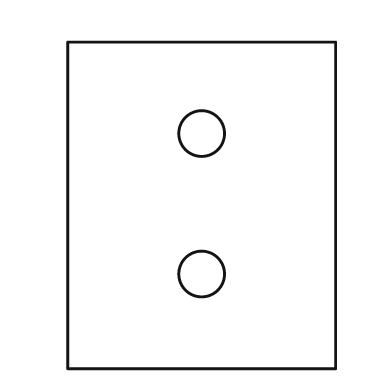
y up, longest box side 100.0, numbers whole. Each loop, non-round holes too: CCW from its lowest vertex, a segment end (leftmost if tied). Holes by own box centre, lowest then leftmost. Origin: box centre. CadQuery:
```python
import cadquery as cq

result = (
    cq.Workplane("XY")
    .moveTo(-41.0, -50.0)
    .lineTo(41.0, -50.0)
    .lineTo(41.0, 50.0)
    .lineTo(-41.0, 50.0)
    .close()
    .moveTo(0.0, -21.0)
    .circle(7.0)
    .moveTo(0.0, 22.0)
    .circle(7.0)
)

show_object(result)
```